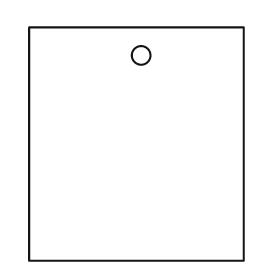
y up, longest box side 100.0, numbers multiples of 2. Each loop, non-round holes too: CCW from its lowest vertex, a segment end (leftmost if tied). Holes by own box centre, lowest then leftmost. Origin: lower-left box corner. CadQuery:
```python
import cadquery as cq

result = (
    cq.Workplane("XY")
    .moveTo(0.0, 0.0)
    .lineTo(92.0, 0.0)
    .lineTo(92.0, 100.0)
    .lineTo(0.0, 100.0)
    .close()
    .moveTo(48.0, 88.0)
    .circle(4.0)
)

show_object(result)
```